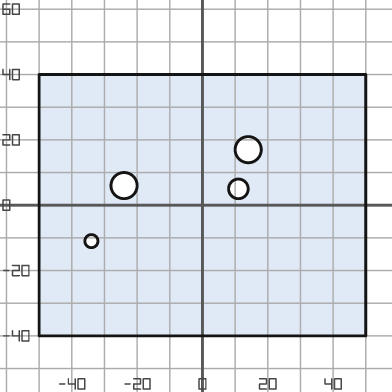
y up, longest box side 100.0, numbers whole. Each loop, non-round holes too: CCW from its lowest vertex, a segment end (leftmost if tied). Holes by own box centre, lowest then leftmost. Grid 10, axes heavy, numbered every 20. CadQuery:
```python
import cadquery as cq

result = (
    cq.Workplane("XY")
    .moveTo(-50.0, -40.0)
    .lineTo(50.0, -40.0)
    .lineTo(50.0, 40.0)
    .lineTo(-50.0, 40.0)
    .close()
    .moveTo(-34.0, -11.0)
    .circle(2.0)
    .moveTo(11.0, 5.0)
    .circle(3.0)
    .moveTo(-24.0, 6.0)
    .circle(4.0)
    .moveTo(14.0, 17.0)
    .circle(4.0)
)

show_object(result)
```